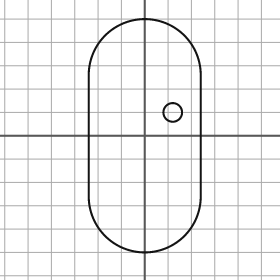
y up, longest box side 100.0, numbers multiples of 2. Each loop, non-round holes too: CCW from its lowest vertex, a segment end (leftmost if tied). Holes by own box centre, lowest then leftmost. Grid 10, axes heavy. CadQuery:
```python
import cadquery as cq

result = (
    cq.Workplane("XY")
    .moveTo(-24.0, -26.0)
    .threePointArc((0.0, -50.0), (24.0, -26.0))
    .lineTo(24.0, 26.0)
    .threePointArc((0.0, 50.0), (-24.0, 26.0))
    .close()
    .moveTo(12.0, 10.0)
    .circle(4.0)
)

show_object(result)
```